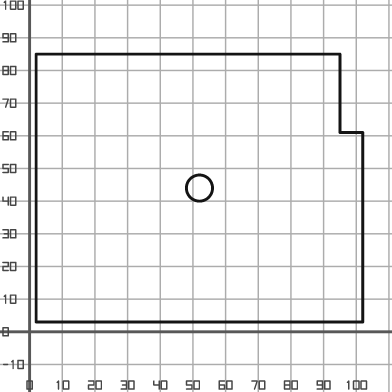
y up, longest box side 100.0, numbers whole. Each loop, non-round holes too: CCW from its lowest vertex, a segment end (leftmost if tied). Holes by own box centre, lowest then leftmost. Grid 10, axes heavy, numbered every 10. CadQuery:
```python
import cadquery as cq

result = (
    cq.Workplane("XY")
    .moveTo(2.0, 3.0)
    .lineTo(102.0, 3.0)
    .lineTo(102.0, 61.0)
    .lineTo(95.0, 61.0)
    .lineTo(95.0, 85.0)
    .lineTo(2.0, 85.0)
    .close()
    .moveTo(52.0, 44.0)
    .circle(4.0)
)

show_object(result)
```